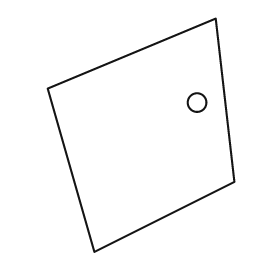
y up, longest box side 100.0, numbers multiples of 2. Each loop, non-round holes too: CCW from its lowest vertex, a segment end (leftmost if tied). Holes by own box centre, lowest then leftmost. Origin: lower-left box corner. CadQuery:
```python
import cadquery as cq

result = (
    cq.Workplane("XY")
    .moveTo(20.0, 0.0)
    .lineTo(80.0, 30.0)
    .lineTo(72.0, 100.0)
    .lineTo(0.0, 70.0)
    .close()
    .moveTo(64.0, 64.0)
    .circle(4.0)
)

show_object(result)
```